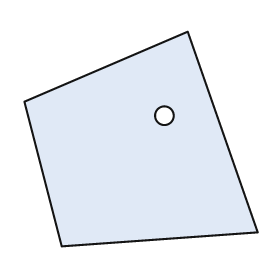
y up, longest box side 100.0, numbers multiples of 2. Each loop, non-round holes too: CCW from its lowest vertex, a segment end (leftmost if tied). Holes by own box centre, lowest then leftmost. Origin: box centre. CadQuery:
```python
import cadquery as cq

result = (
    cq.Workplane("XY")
    .moveTo(-34.0, -46.0)
    .lineTo(50.0, -40.0)
    .lineTo(20.0, 46.0)
    .lineTo(-50.0, 16.0)
    .close()
    .moveTo(10.0, 10.0)
    .circle(4.0)
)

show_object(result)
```